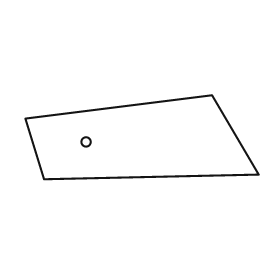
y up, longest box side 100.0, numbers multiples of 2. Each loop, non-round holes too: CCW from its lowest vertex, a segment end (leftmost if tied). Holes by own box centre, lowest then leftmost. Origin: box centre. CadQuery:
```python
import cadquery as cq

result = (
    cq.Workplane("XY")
    .moveTo(-42.0, -18.0)
    .lineTo(50.0, -16.0)
    .lineTo(30.0, 18.0)
    .lineTo(-50.0, 8.0)
    .close()
    .moveTo(-24.0, -2.0)
    .circle(2.0)
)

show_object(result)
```